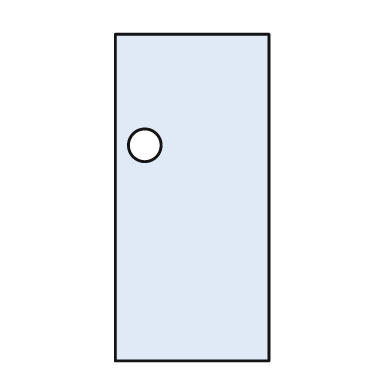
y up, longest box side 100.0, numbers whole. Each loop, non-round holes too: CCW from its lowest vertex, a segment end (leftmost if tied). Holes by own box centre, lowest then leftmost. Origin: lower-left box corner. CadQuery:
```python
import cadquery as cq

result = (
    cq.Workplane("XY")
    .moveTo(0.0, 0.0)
    .lineTo(47.0, 0.0)
    .lineTo(47.0, 100.0)
    .lineTo(0.0, 100.0)
    .close()
    .moveTo(9.0, 66.0)
    .circle(5.0)
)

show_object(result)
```